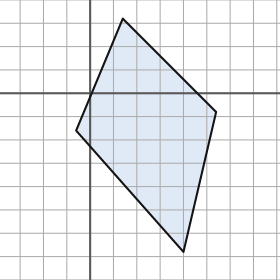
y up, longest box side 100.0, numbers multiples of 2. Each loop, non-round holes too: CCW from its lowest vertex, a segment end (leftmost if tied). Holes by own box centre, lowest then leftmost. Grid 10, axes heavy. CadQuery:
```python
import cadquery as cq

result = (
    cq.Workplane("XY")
    .moveTo(40.0, -68.0)
    .lineTo(54.0, -8.0)
    .lineTo(14.0, 32.0)
    .lineTo(-6.0, -16.0)
    .close()
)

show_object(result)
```